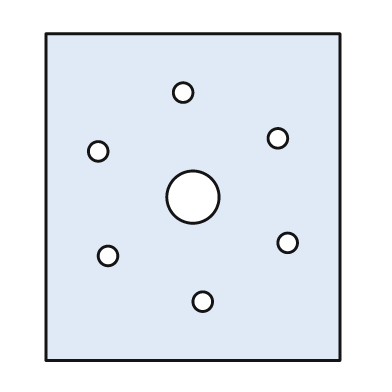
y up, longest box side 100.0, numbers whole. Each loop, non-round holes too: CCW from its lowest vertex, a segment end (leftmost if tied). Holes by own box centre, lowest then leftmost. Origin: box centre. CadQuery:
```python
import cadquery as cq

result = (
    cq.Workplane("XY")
    .moveTo(-45.0, -50.0)
    .lineTo(45.0, -50.0)
    .lineTo(45.0, 50.0)
    .lineTo(-45.0, 50.0)
    .close()
    .moveTo(3.0, -32.0)
    .circle(3.0)
    .moveTo(-26.0, -18.0)
    .circle(3.0)
    .moveTo(29.0, -14.0)
    .circle(3.0)
    .moveTo(0.0, 0.0)
    .circle(8.0)
    .moveTo(-29.0, 14.0)
    .circle(3.0)
    .moveTo(26.0, 18.0)
    .circle(3.0)
    .moveTo(-3.0, 32.0)
    .circle(3.0)
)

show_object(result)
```